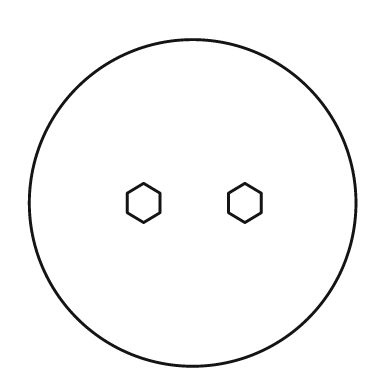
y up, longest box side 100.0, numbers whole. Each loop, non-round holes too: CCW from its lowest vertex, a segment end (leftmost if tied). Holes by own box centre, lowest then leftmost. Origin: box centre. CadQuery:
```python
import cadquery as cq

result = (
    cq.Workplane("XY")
    .moveTo(0.0, 0.0)
    .circle(50.0)
    .moveTo(-15.0, -6.0)
    .lineTo(-10.0, -3.0)
    .lineTo(-10.0, 3.0)
    .lineTo(-15.0, 6.0)
    .lineTo(-20.0, 3.0)
    .lineTo(-20.0, -3.0)
    .close()
    .moveTo(16.0, -6.0)
    .lineTo(21.0, -3.0)
    .lineTo(21.0, 3.0)
    .lineTo(16.0, 6.0)
    .lineTo(11.0, 3.0)
    .lineTo(11.0, -3.0)
    .close()
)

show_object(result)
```